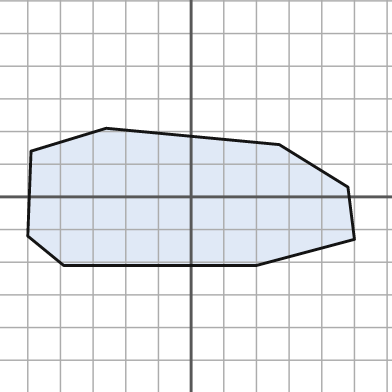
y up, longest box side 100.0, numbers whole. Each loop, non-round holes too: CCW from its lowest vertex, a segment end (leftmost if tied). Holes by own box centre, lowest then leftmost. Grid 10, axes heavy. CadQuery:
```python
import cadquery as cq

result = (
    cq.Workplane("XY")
    .moveTo(-39.0, -21.0)
    .lineTo(20.0, -21.0)
    .lineTo(50.0, -13.0)
    .lineTo(48.0, 3.0)
    .lineTo(27.0, 16.0)
    .lineTo(-26.0, 21.0)
    .lineTo(-49.0, 14.0)
    .lineTo(-50.0, -12.0)
    .close()
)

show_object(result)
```